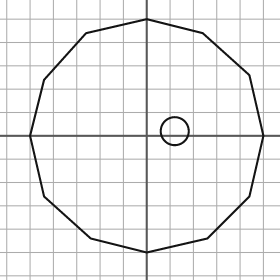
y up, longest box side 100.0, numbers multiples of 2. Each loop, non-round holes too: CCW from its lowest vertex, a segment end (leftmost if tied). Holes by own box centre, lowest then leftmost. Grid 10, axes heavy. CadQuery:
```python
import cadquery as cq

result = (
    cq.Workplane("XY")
    .moveTo(0.0, -50.0)
    .lineTo(26.0, -44.0)
    .lineTo(44.0, -26.0)
    .lineTo(50.0, 0.0)
    .lineTo(44.0, 26.0)
    .lineTo(24.0, 44.0)
    .lineTo(0.0, 50.0)
    .lineTo(-26.0, 44.0)
    .lineTo(-44.0, 24.0)
    .lineTo(-50.0, 0.0)
    .lineTo(-44.0, -26.0)
    .lineTo(-24.0, -44.0)
    .close()
    .moveTo(12.0, 2.0)
    .circle(6.0)
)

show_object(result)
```